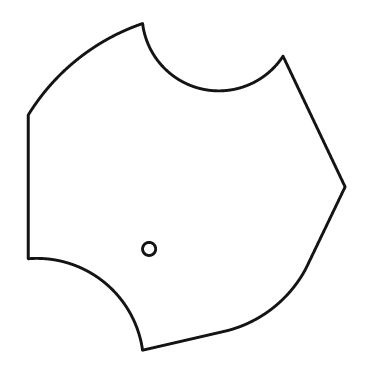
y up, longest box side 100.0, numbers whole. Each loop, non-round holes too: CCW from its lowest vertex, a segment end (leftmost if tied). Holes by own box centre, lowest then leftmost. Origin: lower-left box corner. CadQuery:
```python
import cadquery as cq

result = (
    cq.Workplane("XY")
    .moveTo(35.0, 0.0)
    .lineTo(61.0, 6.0)
    .threePointArc((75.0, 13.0), (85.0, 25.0))
    .lineTo(97.0, 50.0)
    .lineTo(78.0, 90.0)
    .threePointArc((53.0, 80.0), (35.0, 100.0))
    .threePointArc((15.0, 89.0), (0.0, 72.0))
    .lineTo(0.0, 28.0)
    .threePointArc((23.0, 21.0), (35.0, 0.0))
    .close()
    .moveTo(37.0, 31.0)
    .circle(2.0)
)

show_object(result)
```